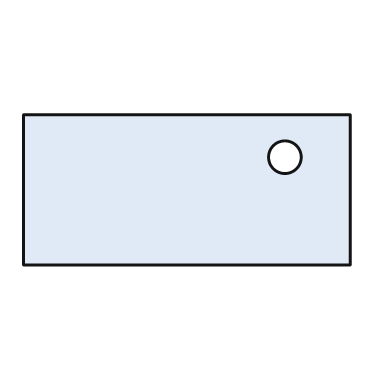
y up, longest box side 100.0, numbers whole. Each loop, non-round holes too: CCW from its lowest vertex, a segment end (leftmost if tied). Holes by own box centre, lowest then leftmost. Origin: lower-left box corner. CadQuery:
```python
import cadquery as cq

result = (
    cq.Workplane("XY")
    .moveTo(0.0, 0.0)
    .lineTo(100.0, 0.0)
    .lineTo(100.0, 46.0)
    .lineTo(0.0, 46.0)
    .close()
    .moveTo(80.0, 33.0)
    .circle(5.0)
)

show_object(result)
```